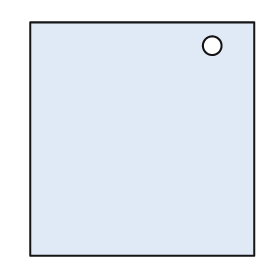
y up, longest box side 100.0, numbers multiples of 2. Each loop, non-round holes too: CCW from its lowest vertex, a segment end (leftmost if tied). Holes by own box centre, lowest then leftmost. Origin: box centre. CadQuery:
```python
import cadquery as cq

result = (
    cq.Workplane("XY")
    .moveTo(-48.0, -50.0)
    .lineTo(48.0, -50.0)
    .lineTo(48.0, 50.0)
    .lineTo(-48.0, 50.0)
    .close()
    .moveTo(30.0, 40.0)
    .circle(4.0)
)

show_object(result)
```